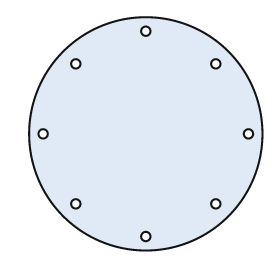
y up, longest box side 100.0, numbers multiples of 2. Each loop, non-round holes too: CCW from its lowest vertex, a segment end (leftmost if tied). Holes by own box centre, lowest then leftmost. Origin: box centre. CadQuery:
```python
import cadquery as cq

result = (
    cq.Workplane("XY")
    .moveTo(0.0, 0.0)
    .circle(50.0)
    .moveTo(0.0, -44.0)
    .circle(2.0)
    .moveTo(-30.0, -30.0)
    .circle(2.0)
    .moveTo(30.0, -30.0)
    .circle(2.0)
    .moveTo(-44.0, 0.0)
    .circle(2.0)
    .moveTo(44.0, 0.0)
    .circle(2.0)
    .moveTo(-30.0, 30.0)
    .circle(2.0)
    .moveTo(30.0, 30.0)
    .circle(2.0)
    .moveTo(0.0, 44.0)
    .circle(2.0)
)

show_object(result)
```